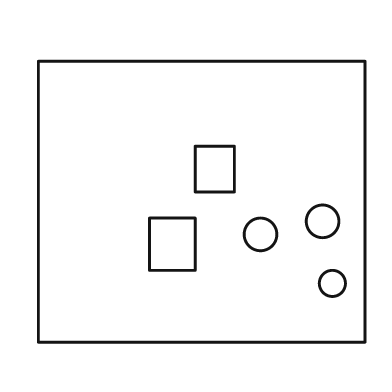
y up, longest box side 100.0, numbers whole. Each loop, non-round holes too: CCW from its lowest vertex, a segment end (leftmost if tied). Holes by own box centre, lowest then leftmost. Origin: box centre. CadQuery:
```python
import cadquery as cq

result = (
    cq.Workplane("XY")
    .moveTo(-50.0, -43.0)
    .lineTo(50.0, -43.0)
    .lineTo(50.0, 43.0)
    .lineTo(-50.0, 43.0)
    .close()
    .moveTo(40.0, -25.0)
    .circle(4.0)
    .moveTo(-16.0, -21.0)
    .lineTo(-2.0, -21.0)
    .lineTo(-2.0, -5.0)
    .lineTo(-16.0, -5.0)
    .close()
    .moveTo(18.0, -10.0)
    .circle(5.0)
    .moveTo(37.0, -6.0)
    .circle(5.0)
    .moveTo(-2.0, 3.0)
    .lineTo(10.0, 3.0)
    .lineTo(10.0, 17.0)
    .lineTo(-2.0, 17.0)
    .close()
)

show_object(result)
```